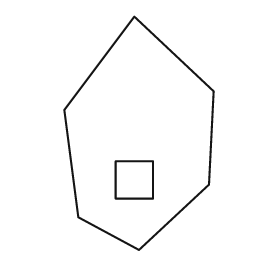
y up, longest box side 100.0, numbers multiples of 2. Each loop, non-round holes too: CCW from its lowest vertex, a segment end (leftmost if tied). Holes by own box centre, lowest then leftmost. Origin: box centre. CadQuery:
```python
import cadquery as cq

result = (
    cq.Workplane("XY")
    .moveTo(0.0, -50.0)
    .lineTo(30.0, -22.0)
    .lineTo(32.0, 18.0)
    .lineTo(-2.0, 50.0)
    .lineTo(-32.0, 10.0)
    .lineTo(-26.0, -36.0)
    .close()
    .moveTo(-10.0, -28.0)
    .lineTo(6.0, -28.0)
    .lineTo(6.0, -12.0)
    .lineTo(-10.0, -12.0)
    .close()
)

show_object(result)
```